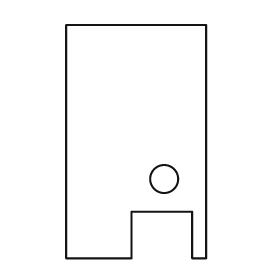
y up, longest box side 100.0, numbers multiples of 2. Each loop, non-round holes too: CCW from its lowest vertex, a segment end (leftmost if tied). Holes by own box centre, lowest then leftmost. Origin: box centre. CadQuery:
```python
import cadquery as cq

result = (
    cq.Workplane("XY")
    .moveTo(-30.0, -50.0)
    .lineTo(-2.0, -50.0)
    .lineTo(-2.0, -30.0)
    .lineTo(24.0, -30.0)
    .lineTo(24.0, -50.0)
    .lineTo(30.0, -50.0)
    .lineTo(30.0, 50.0)
    .lineTo(-30.0, 50.0)
    .close()
    .moveTo(12.0, -16.0)
    .circle(6.0)
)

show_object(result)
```